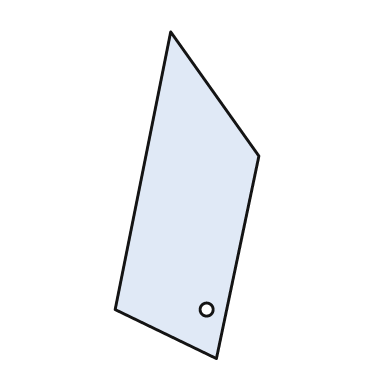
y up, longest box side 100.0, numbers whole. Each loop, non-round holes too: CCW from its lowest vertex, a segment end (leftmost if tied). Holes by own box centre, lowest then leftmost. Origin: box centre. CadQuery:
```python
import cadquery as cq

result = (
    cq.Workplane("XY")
    .moveTo(9.0, -50.0)
    .lineTo(22.0, 12.0)
    .lineTo(-5.0, 50.0)
    .lineTo(-22.0, -35.0)
    .close()
    .moveTo(6.0, -35.0)
    .circle(2.0)
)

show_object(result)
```